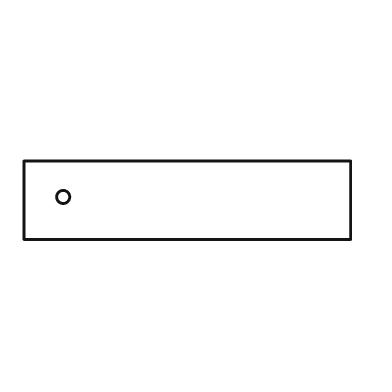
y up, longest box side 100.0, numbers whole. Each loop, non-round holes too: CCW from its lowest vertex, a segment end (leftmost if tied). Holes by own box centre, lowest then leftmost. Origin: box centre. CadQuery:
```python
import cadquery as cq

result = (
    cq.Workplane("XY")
    .moveTo(-50.0, -12.0)
    .lineTo(50.0, -12.0)
    .lineTo(50.0, 12.0)
    .lineTo(-50.0, 12.0)
    .close()
    .moveTo(-38.0, 1.0)
    .circle(2.0)
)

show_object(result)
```